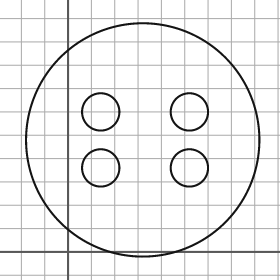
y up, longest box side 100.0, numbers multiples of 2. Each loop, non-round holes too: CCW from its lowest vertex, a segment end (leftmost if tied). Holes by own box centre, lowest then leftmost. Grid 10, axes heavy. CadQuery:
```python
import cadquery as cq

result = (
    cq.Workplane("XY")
    .moveTo(32.0, 48.0)
    .circle(50.0)
    .moveTo(14.0, 36.0)
    .circle(8.0)
    .moveTo(52.0, 36.0)
    .circle(8.0)
    .moveTo(14.0, 60.0)
    .circle(8.0)
    .moveTo(52.0, 60.0)
    .circle(8.0)
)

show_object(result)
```